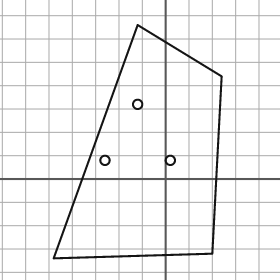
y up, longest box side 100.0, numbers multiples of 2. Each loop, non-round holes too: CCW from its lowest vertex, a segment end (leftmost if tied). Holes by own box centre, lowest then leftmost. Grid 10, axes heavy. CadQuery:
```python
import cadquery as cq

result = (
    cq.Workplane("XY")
    .moveTo(-48.0, -34.0)
    .lineTo(20.0, -32.0)
    .lineTo(24.0, 44.0)
    .lineTo(-12.0, 66.0)
    .close()
    .moveTo(-26.0, 8.0)
    .circle(2.0)
    .moveTo(2.0, 8.0)
    .circle(2.0)
    .moveTo(-12.0, 32.0)
    .circle(2.0)
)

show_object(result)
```